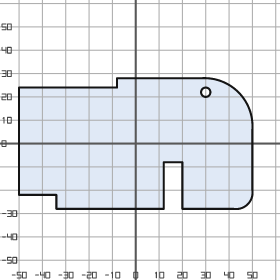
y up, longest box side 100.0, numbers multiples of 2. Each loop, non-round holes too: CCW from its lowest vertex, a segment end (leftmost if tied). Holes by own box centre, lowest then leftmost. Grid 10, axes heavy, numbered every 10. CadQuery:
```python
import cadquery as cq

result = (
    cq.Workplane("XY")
    .moveTo(-34.0, -28.0)
    .lineTo(12.0, -28.0)
    .lineTo(12.0, -8.0)
    .lineTo(20.0, -8.0)
    .lineTo(20.0, -28.0)
    .lineTo(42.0, -28.0)
    .threePointArc((48.0, -26.0), (50.0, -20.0))
    .lineTo(50.0, 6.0)
    .threePointArc((44.0, 22.0), (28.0, 28.0))
    .lineTo(-8.0, 28.0)
    .lineTo(-8.0, 24.0)
    .lineTo(-50.0, 24.0)
    .lineTo(-50.0, -22.0)
    .lineTo(-34.0, -22.0)
    .close()
    .moveTo(30.0, 22.0)
    .circle(2.0)
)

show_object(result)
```